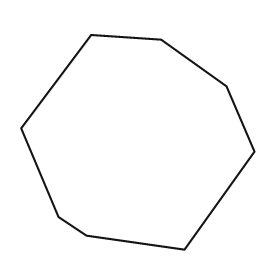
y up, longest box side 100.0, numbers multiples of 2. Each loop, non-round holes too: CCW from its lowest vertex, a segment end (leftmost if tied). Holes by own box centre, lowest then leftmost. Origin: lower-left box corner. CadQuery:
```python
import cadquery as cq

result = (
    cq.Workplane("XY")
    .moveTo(70.0, 0.0)
    .lineTo(100.0, 42.0)
    .lineTo(88.0, 70.0)
    .lineTo(60.0, 90.0)
    .lineTo(30.0, 92.0)
    .lineTo(0.0, 52.0)
    .lineTo(16.0, 14.0)
    .lineTo(28.0, 6.0)
    .close()
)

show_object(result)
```